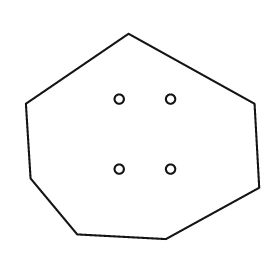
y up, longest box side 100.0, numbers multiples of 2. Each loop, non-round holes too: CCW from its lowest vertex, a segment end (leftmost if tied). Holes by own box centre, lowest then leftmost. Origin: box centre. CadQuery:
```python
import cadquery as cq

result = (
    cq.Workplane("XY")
    .moveTo(10.0, -44.0)
    .lineTo(50.0, -22.0)
    .lineTo(48.0, 14.0)
    .lineTo(-6.0, 44.0)
    .lineTo(-50.0, 14.0)
    .lineTo(-48.0, -18.0)
    .lineTo(-28.0, -42.0)
    .close()
    .moveTo(-10.0, -14.0)
    .circle(2.0)
    .moveTo(12.0, -14.0)
    .circle(2.0)
    .moveTo(-10.0, 16.0)
    .circle(2.0)
    .moveTo(12.0, 16.0)
    .circle(2.0)
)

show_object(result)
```